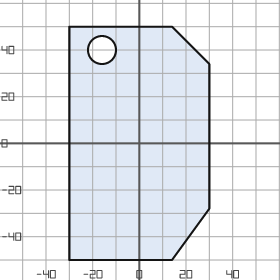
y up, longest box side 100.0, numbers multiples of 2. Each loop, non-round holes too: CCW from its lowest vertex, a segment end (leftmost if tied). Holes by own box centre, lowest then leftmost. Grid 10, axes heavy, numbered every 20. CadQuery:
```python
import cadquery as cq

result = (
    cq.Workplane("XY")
    .moveTo(-30.0, -50.0)
    .lineTo(14.0, -50.0)
    .lineTo(30.0, -28.0)
    .lineTo(30.0, 34.0)
    .lineTo(14.0, 50.0)
    .lineTo(-30.0, 50.0)
    .close()
    .moveTo(-16.0, 40.0)
    .circle(6.0)
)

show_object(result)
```